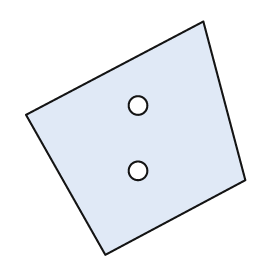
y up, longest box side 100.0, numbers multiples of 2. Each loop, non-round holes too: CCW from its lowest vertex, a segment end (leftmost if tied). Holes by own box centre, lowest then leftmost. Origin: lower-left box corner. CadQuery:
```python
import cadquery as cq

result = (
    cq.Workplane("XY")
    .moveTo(34.0, 0.0)
    .lineTo(94.0, 32.0)
    .lineTo(76.0, 100.0)
    .lineTo(0.0, 60.0)
    .close()
    .moveTo(48.0, 36.0)
    .circle(4.0)
    .moveTo(48.0, 64.0)
    .circle(4.0)
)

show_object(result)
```